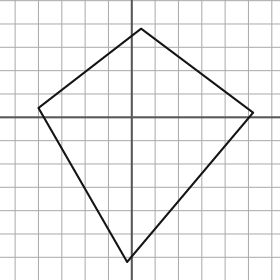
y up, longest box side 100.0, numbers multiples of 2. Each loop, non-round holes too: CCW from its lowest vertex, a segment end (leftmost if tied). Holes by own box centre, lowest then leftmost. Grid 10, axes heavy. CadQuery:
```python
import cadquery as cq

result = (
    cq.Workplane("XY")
    .moveTo(-2.0, -62.0)
    .lineTo(52.0, 2.0)
    .lineTo(4.0, 38.0)
    .lineTo(-40.0, 4.0)
    .close()
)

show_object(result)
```